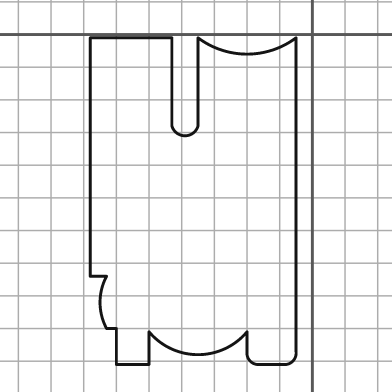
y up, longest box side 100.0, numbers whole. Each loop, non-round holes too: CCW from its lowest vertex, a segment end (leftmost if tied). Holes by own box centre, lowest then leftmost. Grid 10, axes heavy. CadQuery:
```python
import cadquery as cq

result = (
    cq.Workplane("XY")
    .moveTo(-60.0, -101.0)
    .lineTo(-50.0, -101.0)
    .lineTo(-50.0, -91.0)
    .threePointArc((-35.0, -98.0), (-20.0, -91.0))
    .lineTo(-20.0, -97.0)
    .threePointArc((-19.0, -100.0), (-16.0, -101.0))
    .lineTo(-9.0, -101.0)
    .threePointArc((-6.0, -100.0), (-5.0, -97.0))
    .lineTo(-5.0, -1.0)
    .threePointArc((-20.0, -6.0), (-35.0, -1.0))
    .lineTo(-35.0, -28.0)
    .threePointArc((-39.0, -31.0), (-43.0, -28.0))
    .lineTo(-43.0, -1.0)
    .lineTo(-68.0, -1.0)
    .lineTo(-68.0, -74.0)
    .lineTo(-63.0, -74.0)
    .threePointArc((-65.0, -82.0), (-63.0, -90.0))
    .lineTo(-60.0, -90.0)
    .close()
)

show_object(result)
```